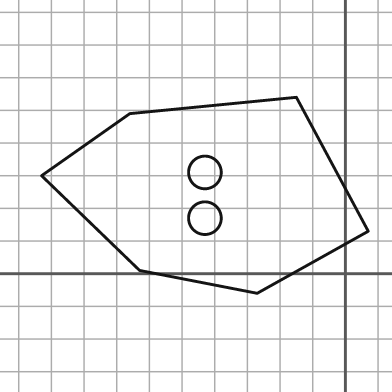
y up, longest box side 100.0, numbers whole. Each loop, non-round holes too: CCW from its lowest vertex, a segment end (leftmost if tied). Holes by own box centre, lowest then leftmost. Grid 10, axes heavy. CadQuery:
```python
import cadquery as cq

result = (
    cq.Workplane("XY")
    .moveTo(-27.0, -6.0)
    .lineTo(7.0, 13.0)
    .lineTo(-15.0, 54.0)
    .lineTo(-66.0, 49.0)
    .lineTo(-93.0, 30.0)
    .lineTo(-63.0, 1.0)
    .close()
    .moveTo(-43.0, 17.0)
    .circle(5.0)
    .moveTo(-43.0, 31.0)
    .circle(5.0)
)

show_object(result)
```